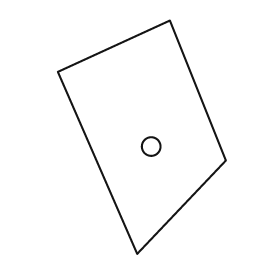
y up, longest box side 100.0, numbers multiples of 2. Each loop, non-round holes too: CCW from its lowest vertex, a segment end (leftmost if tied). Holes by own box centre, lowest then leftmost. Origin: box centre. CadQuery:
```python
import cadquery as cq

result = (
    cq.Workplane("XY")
    .moveTo(-2.0, -50.0)
    .lineTo(36.0, -10.0)
    .lineTo(12.0, 50.0)
    .lineTo(-36.0, 28.0)
    .close()
    .moveTo(4.0, -4.0)
    .circle(4.0)
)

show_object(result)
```